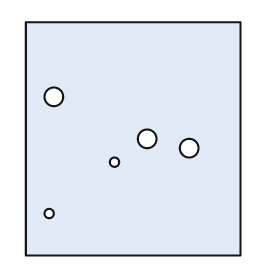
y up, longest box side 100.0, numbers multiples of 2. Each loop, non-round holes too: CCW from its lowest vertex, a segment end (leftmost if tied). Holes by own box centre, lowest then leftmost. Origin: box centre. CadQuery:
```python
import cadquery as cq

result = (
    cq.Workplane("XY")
    .moveTo(-46.0, -50.0)
    .lineTo(46.0, -50.0)
    .lineTo(46.0, 50.0)
    .lineTo(-46.0, 50.0)
    .close()
    .moveTo(-36.0, -32.0)
    .circle(2.0)
    .moveTo(-8.0, -10.0)
    .circle(2.0)
    .moveTo(24.0, -4.0)
    .circle(4.0)
    .moveTo(6.0, 0.0)
    .circle(4.0)
    .moveTo(-34.0, 18.0)
    .circle(4.0)
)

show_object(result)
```